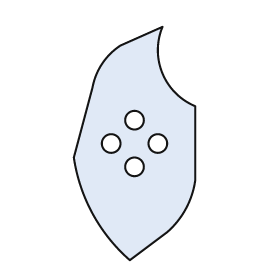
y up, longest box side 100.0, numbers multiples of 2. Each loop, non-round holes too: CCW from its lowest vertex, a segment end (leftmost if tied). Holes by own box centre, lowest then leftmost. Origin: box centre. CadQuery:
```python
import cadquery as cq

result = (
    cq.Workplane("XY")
    .moveTo(-2.0, -50.0)
    .lineTo(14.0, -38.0)
    .threePointArc((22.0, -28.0), (26.0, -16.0))
    .lineTo(26.0, 16.0)
    .threePointArc((12.0, 30.0), (12.0, 50.0))
    .lineTo(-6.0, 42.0)
    .threePointArc((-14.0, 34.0), (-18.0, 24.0))
    .lineTo(-26.0, -6.0)
    .threePointArc((-18.0, -30.0), (-2.0, -50.0))
    .close()
    .moveTo(0.0, -10.0)
    .circle(4.0)
    .moveTo(-10.0, 0.0)
    .circle(4.0)
    .moveTo(10.0, 0.0)
    .circle(4.0)
    .moveTo(0.0, 10.0)
    .circle(4.0)
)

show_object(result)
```